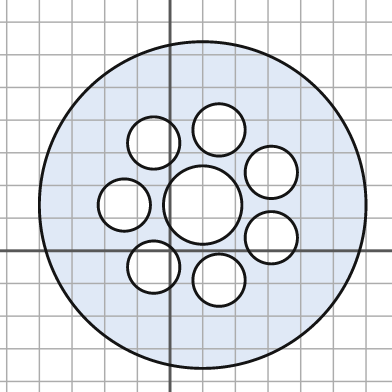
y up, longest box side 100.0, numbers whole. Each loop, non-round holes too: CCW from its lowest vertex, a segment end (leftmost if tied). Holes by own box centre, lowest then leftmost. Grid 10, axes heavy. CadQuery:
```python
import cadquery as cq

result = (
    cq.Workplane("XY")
    .moveTo(10.0, 14.0)
    .circle(50.0)
    .moveTo(15.0, -9.0)
    .circle(8.0)
    .moveTo(-5.0, -5.0)
    .circle(8.0)
    .moveTo(31.0, 4.0)
    .circle(8.0)
    .moveTo(-14.0, 14.0)
    .circle(8.0)
    .moveTo(10.0, 14.0)
    .circle(12.0)
    .moveTo(31.0, 24.0)
    .circle(8.0)
    .moveTo(-5.0, 33.0)
    .circle(8.0)
    .moveTo(15.0, 37.0)
    .circle(8.0)
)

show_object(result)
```